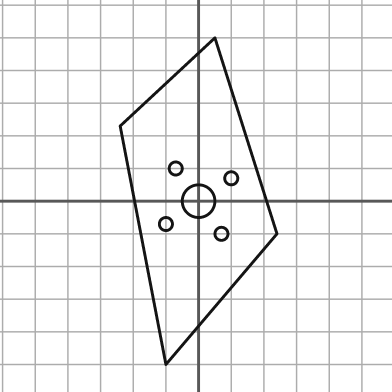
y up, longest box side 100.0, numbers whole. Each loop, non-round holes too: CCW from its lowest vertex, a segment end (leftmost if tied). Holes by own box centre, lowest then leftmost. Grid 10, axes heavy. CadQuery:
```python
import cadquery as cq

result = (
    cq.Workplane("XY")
    .moveTo(-10.0, -50.0)
    .lineTo(24.0, -10.0)
    .lineTo(5.0, 50.0)
    .lineTo(-24.0, 23.0)
    .close()
    .moveTo(7.0, -10.0)
    .circle(2.0)
    .moveTo(-10.0, -7.0)
    .circle(2.0)
    .moveTo(0.0, 0.0)
    .circle(5.0)
    .moveTo(10.0, 7.0)
    .circle(2.0)
    .moveTo(-7.0, 10.0)
    .circle(2.0)
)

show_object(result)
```